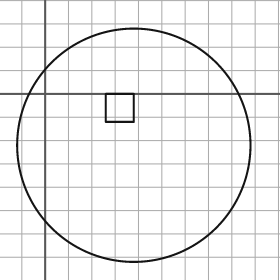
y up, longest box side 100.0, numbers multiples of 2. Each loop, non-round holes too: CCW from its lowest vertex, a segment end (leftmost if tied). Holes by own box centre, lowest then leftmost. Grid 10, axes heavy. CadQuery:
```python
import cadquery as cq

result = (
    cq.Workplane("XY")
    .moveTo(38.0, -22.0)
    .circle(50.0)
    .moveTo(26.0, -12.0)
    .lineTo(38.0, -12.0)
    .lineTo(38.0, 0.0)
    .lineTo(26.0, 0.0)
    .close()
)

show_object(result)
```